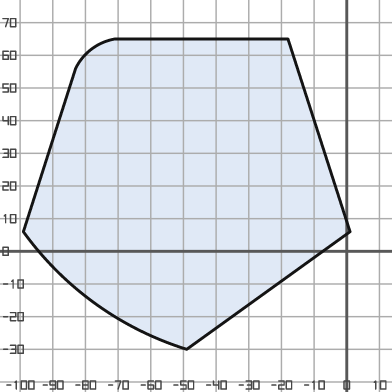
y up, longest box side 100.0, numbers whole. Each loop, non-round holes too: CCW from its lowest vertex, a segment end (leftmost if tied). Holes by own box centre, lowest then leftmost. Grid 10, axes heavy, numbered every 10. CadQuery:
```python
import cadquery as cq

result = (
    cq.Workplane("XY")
    .moveTo(-49.0, -30.0)
    .lineTo(1.0, 6.0)
    .lineTo(-18.0, 65.0)
    .lineTo(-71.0, 65.0)
    .threePointArc((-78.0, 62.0), (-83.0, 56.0))
    .lineTo(-99.0, 6.0)
    .threePointArc((-77.0, -16.0), (-49.0, -30.0))
    .close()
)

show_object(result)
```